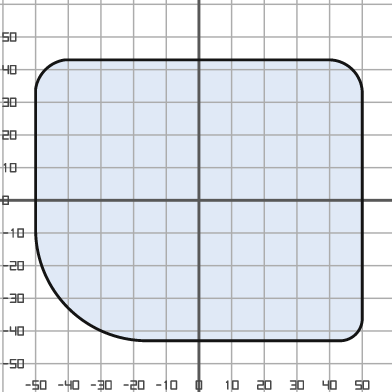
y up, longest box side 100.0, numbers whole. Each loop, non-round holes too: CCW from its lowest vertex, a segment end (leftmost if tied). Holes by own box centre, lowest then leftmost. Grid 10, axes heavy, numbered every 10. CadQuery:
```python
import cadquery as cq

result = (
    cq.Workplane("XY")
    .moveTo(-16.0, -43.0)
    .lineTo(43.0, -43.0)
    .threePointArc((48.0, -41.0), (50.0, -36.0))
    .lineTo(50.0, 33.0)
    .threePointArc((47.0, 40.0), (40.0, 43.0))
    .lineTo(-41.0, 43.0)
    .threePointArc((-47.0, 40.0), (-50.0, 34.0))
    .lineTo(-50.0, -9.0)
    .threePointArc((-40.0, -33.0), (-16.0, -43.0))
    .close()
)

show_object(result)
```